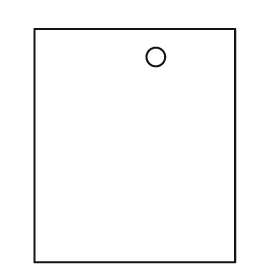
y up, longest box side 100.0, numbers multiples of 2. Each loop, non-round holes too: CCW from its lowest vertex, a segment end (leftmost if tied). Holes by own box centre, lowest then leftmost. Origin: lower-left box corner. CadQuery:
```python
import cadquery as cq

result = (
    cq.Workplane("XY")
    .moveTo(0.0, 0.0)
    .lineTo(86.0, 0.0)
    .lineTo(86.0, 100.0)
    .lineTo(0.0, 100.0)
    .close()
    .moveTo(52.0, 88.0)
    .circle(4.0)
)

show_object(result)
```